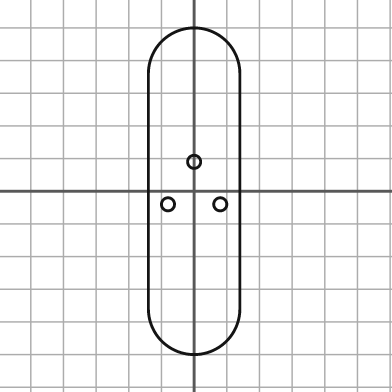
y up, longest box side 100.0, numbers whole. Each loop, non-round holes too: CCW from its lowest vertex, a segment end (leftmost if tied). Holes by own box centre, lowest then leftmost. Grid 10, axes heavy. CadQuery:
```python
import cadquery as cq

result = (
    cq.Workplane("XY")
    .moveTo(-14.0, -36.0)
    .threePointArc((0.0, -50.0), (14.0, -36.0))
    .lineTo(14.0, 36.0)
    .threePointArc((0.0, 50.0), (-14.0, 36.0))
    .close()
    .moveTo(-8.0, -4.0)
    .circle(2.0)
    .moveTo(8.0, -4.0)
    .circle(2.0)
    .moveTo(0.0, 9.0)
    .circle(2.0)
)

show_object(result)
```